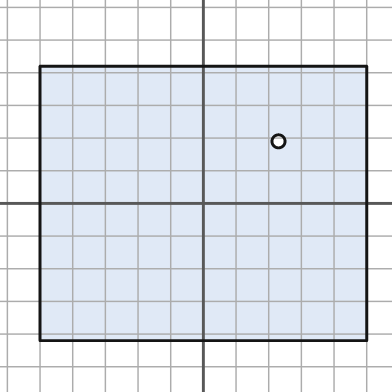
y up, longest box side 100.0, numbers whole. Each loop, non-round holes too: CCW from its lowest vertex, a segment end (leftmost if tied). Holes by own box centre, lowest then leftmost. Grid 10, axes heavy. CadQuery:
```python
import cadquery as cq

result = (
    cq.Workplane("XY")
    .moveTo(-50.0, -42.0)
    .lineTo(50.0, -42.0)
    .lineTo(50.0, 42.0)
    .lineTo(-50.0, 42.0)
    .close()
    .moveTo(23.0, 19.0)
    .circle(2.0)
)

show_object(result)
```